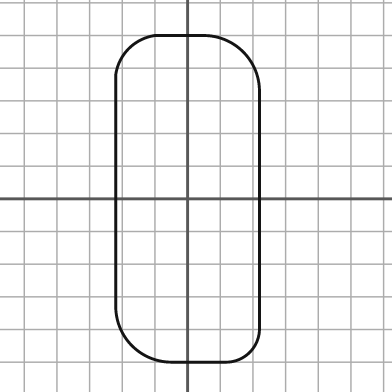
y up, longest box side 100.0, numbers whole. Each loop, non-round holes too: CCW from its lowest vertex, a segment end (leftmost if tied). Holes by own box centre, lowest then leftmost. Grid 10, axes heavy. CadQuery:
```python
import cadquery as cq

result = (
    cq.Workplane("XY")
    .moveTo(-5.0, -50.0)
    .lineTo(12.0, -50.0)
    .threePointArc((19.0, -47.0), (22.0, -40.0))
    .lineTo(22.0, 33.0)
    .threePointArc((17.0, 45.0), (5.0, 50.0))
    .lineTo(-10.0, 50.0)
    .threePointArc((-18.0, 46.0), (-22.0, 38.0))
    .lineTo(-22.0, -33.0)
    .threePointArc((-17.0, -45.0), (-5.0, -50.0))
    .close()
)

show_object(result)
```